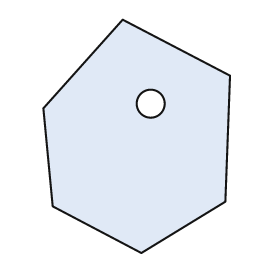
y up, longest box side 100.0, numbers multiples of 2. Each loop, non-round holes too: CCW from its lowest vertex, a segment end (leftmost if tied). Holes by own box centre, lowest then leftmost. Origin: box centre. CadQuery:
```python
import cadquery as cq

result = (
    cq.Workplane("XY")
    .moveTo(2.0, -50.0)
    .lineTo(38.0, -28.0)
    .lineTo(40.0, 26.0)
    .lineTo(-6.0, 50.0)
    .lineTo(-40.0, 12.0)
    .lineTo(-36.0, -30.0)
    .close()
    .moveTo(6.0, 14.0)
    .circle(6.0)
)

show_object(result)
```